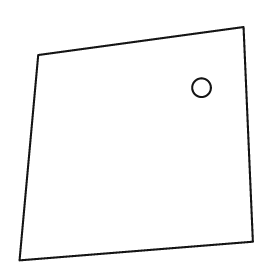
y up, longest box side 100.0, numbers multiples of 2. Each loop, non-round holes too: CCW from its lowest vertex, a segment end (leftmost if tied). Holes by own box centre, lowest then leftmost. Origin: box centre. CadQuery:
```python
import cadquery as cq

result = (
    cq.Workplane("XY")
    .moveTo(-50.0, -50.0)
    .lineTo(50.0, -42.0)
    .lineTo(46.0, 50.0)
    .lineTo(-42.0, 38.0)
    .close()
    .moveTo(28.0, 24.0)
    .circle(4.0)
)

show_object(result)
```